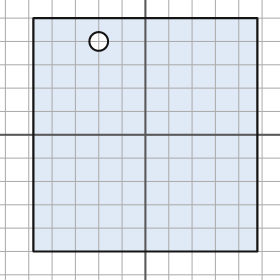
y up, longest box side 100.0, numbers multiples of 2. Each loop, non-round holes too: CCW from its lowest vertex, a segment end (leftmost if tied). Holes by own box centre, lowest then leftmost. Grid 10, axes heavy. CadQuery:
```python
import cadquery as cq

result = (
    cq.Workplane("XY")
    .moveTo(-48.0, -50.0)
    .lineTo(48.0, -50.0)
    .lineTo(48.0, 50.0)
    .lineTo(-48.0, 50.0)
    .close()
    .moveTo(-20.0, 40.0)
    .circle(4.0)
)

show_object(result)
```